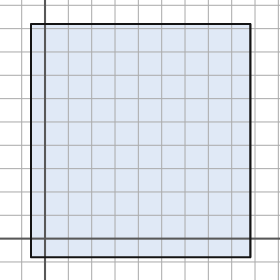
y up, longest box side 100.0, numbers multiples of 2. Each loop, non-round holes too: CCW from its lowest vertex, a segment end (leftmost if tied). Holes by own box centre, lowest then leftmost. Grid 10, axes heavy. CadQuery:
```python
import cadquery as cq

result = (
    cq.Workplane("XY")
    .moveTo(-6.0, -8.0)
    .lineTo(88.0, -8.0)
    .lineTo(88.0, 92.0)
    .lineTo(-6.0, 92.0)
    .close()
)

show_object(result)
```